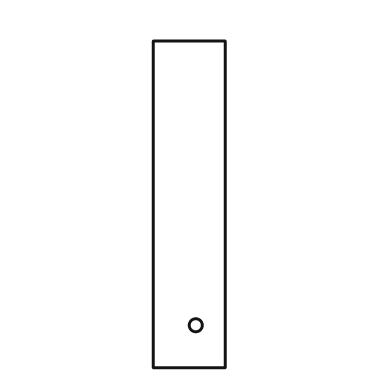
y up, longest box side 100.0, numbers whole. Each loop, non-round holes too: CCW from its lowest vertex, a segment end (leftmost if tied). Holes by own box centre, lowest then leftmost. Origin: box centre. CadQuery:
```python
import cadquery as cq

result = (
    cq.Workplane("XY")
    .moveTo(-11.0, -50.0)
    .lineTo(11.0, -50.0)
    .lineTo(11.0, 50.0)
    .lineTo(-11.0, 50.0)
    .close()
    .moveTo(2.0, -37.0)
    .circle(2.0)
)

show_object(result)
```